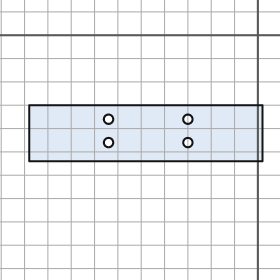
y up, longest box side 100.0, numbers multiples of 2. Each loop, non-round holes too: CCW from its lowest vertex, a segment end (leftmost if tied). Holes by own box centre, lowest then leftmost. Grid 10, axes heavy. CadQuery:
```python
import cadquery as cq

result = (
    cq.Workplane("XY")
    .moveTo(-98.0, -54.0)
    .lineTo(2.0, -54.0)
    .lineTo(2.0, -30.0)
    .lineTo(-98.0, -30.0)
    .close()
    .moveTo(-64.0, -46.0)
    .circle(2.0)
    .moveTo(-30.0, -46.0)
    .circle(2.0)
    .moveTo(-64.0, -36.0)
    .circle(2.0)
    .moveTo(-30.0, -36.0)
    .circle(2.0)
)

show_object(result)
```